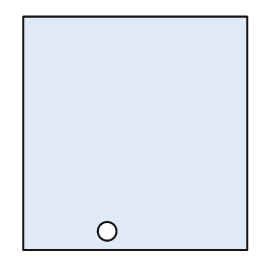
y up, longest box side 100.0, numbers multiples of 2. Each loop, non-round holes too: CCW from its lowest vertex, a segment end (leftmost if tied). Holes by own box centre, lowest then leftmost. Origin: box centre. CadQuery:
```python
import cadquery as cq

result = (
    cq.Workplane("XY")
    .moveTo(-48.0, -50.0)
    .lineTo(48.0, -50.0)
    .lineTo(48.0, 50.0)
    .lineTo(-48.0, 50.0)
    .close()
    .moveTo(-12.0, -42.0)
    .circle(4.0)
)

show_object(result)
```